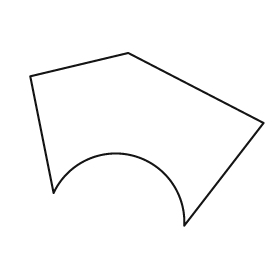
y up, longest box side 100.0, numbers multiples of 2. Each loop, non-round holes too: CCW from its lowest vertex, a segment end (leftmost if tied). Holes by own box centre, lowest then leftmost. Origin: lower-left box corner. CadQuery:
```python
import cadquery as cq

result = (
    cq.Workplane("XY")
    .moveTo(66.0, 0.0)
    .lineTo(100.0, 44.0)
    .lineTo(42.0, 74.0)
    .lineTo(0.0, 64.0)
    .lineTo(10.0, 14.0)
    .threePointArc((44.0, 30.0), (66.0, 0.0))
    .close()
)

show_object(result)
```